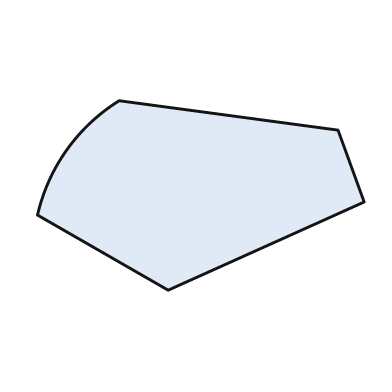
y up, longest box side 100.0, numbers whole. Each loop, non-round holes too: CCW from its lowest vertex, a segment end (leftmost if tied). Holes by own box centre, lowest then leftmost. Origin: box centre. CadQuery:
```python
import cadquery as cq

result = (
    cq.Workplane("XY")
    .moveTo(-10.0, -29.0)
    .lineTo(50.0, -2.0)
    .lineTo(42.0, 20.0)
    .lineTo(-25.0, 29.0)
    .threePointArc((-41.0, 14.0), (-50.0, -6.0))
    .close()
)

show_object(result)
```